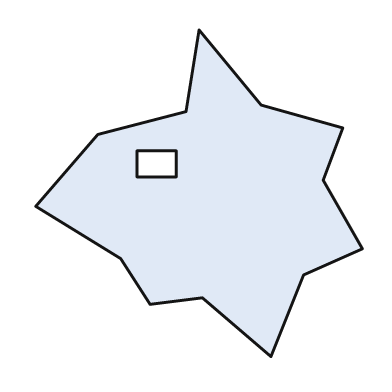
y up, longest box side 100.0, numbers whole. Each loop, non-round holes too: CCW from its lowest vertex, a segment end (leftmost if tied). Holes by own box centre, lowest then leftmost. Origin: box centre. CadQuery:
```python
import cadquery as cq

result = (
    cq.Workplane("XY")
    .moveTo(22.0, -50.0)
    .lineTo(32.0, -25.0)
    .lineTo(50.0, -17.0)
    .lineTo(38.0, 4.0)
    .lineTo(44.0, 20.0)
    .lineTo(19.0, 27.0)
    .lineTo(0.0, 50.0)
    .lineTo(-4.0, 25.0)
    .lineTo(-31.0, 18.0)
    .lineTo(-50.0, -4.0)
    .lineTo(-24.0, -20.0)
    .lineTo(-15.0, -34.0)
    .lineTo(1.0, -32.0)
    .close()
    .moveTo(-19.0, 5.0)
    .lineTo(-7.0, 5.0)
    .lineTo(-7.0, 13.0)
    .lineTo(-19.0, 13.0)
    .close()
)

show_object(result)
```